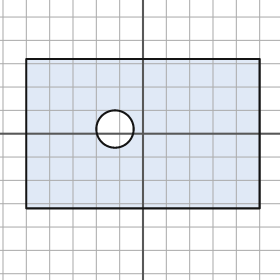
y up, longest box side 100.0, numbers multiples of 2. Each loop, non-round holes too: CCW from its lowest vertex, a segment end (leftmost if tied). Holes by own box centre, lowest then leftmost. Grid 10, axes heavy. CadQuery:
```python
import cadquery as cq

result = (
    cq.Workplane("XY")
    .moveTo(-50.0, -32.0)
    .lineTo(50.0, -32.0)
    .lineTo(50.0, 32.0)
    .lineTo(-50.0, 32.0)
    .close()
    .moveTo(-12.0, 2.0)
    .circle(8.0)
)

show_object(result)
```